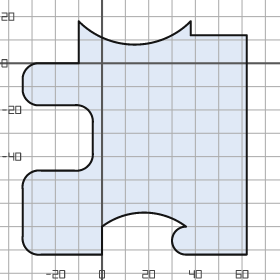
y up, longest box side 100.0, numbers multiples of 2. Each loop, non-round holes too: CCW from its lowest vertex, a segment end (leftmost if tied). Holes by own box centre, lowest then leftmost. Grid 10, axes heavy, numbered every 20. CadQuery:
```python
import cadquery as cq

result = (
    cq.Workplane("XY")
    .moveTo(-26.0, -82.0)
    .lineTo(0.0, -82.0)
    .lineTo(0.0, -70.0)
    .threePointArc((18.0, -64.0), (36.0, -70.0))
    .threePointArc((30.0, -76.0), (36.0, -82.0))
    .lineTo(62.0, -82.0)
    .lineTo(62.0, 12.0)
    .lineTo(38.0, 12.0)
    .lineTo(38.0, 18.0)
    .threePointArc((14.0, 8.0), (-10.0, 18.0))
    .lineTo(-10.0, 0.0)
    .lineTo(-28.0, 0.0)
    .threePointArc((-32.0, -2.0), (-34.0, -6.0))
    .lineTo(-34.0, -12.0)
    .threePointArc((-32.0, -16.0), (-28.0, -18.0))
    .lineTo(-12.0, -18.0)
    .threePointArc((-6.0, -20.0), (-4.0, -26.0))
    .lineTo(-4.0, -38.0)
    .threePointArc((-6.0, -44.0), (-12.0, -46.0))
    .lineTo(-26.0, -46.0)
    .threePointArc((-32.0, -48.0), (-34.0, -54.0))
    .lineTo(-34.0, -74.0)
    .threePointArc((-32.0, -80.0), (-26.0, -82.0))
    .close()
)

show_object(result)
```